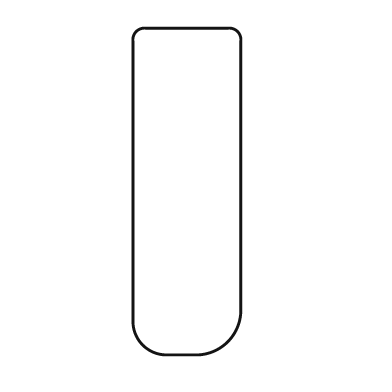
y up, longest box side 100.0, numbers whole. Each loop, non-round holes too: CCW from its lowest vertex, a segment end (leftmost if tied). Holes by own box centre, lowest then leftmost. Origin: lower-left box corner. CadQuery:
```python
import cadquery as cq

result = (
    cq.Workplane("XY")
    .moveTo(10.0, 0.0)
    .lineTo(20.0, 0.0)
    .threePointArc((29.0, 4.0), (33.0, 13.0))
    .lineTo(33.0, 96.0)
    .threePointArc((32.0, 99.0), (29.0, 100.0))
    .lineTo(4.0, 100.0)
    .threePointArc((1.0, 99.0), (0.0, 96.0))
    .lineTo(0.0, 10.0)
    .threePointArc((3.0, 3.0), (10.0, 0.0))
    .close()
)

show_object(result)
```